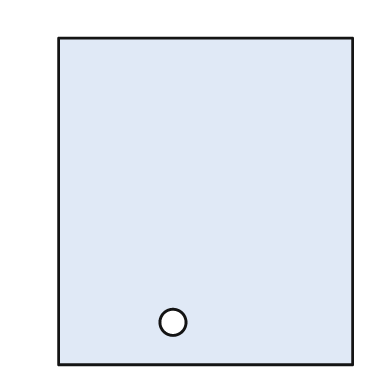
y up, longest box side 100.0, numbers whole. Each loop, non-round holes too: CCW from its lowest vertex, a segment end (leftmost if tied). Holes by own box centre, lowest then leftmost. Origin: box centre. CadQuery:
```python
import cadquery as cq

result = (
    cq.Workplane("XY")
    .moveTo(-45.0, -50.0)
    .lineTo(45.0, -50.0)
    .lineTo(45.0, 50.0)
    .lineTo(-45.0, 50.0)
    .close()
    .moveTo(-10.0, -37.0)
    .circle(4.0)
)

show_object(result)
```